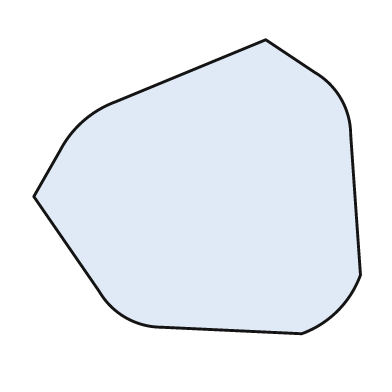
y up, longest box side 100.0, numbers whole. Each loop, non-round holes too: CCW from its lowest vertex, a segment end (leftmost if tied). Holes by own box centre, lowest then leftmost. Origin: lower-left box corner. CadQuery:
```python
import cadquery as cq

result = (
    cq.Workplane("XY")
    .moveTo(82.0, 0.0)
    .threePointArc((93.0, 7.0), (100.0, 18.0))
    .lineTo(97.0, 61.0)
    .threePointArc((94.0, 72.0), (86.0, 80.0))
    .lineTo(71.0, 90.0)
    .lineTo(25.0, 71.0)
    .threePointArc((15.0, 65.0), (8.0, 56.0))
    .lineTo(0.0, 42.0)
    .lineTo(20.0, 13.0)
    .threePointArc((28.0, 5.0), (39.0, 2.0))
    .close()
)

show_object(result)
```